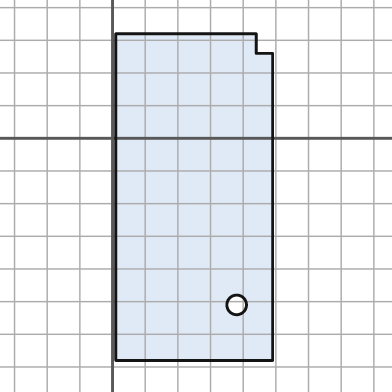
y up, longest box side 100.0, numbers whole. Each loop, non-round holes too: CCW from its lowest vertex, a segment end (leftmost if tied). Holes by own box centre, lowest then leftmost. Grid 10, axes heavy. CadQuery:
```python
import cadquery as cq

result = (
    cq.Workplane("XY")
    .moveTo(1.0, -68.0)
    .lineTo(49.0, -68.0)
    .lineTo(49.0, 26.0)
    .lineTo(44.0, 26.0)
    .lineTo(44.0, 32.0)
    .lineTo(1.0, 32.0)
    .close()
    .moveTo(38.0, -51.0)
    .circle(3.0)
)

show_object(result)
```